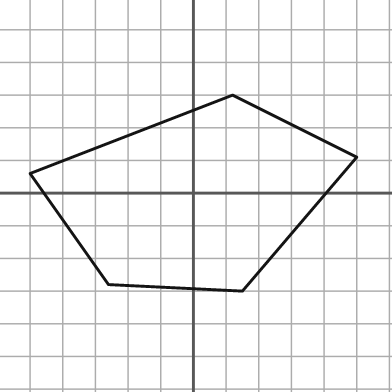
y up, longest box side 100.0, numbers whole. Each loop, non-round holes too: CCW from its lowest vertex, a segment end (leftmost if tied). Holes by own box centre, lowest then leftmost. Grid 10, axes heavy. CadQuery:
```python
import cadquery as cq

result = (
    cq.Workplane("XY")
    .moveTo(15.0, -30.0)
    .lineTo(50.0, 11.0)
    .lineTo(12.0, 30.0)
    .lineTo(-50.0, 6.0)
    .lineTo(-26.0, -28.0)
    .close()
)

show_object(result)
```